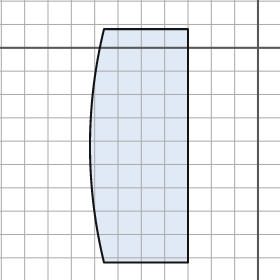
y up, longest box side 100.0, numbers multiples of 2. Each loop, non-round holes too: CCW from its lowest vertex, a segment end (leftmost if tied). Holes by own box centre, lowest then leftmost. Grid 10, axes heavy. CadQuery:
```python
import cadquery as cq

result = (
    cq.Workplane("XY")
    .moveTo(-66.0, -92.0)
    .lineTo(-30.0, -92.0)
    .lineTo(-30.0, 8.0)
    .lineTo(-66.0, 8.0)
    .threePointArc((-72.0, -42.0), (-66.0, -92.0))
    .close()
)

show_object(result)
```